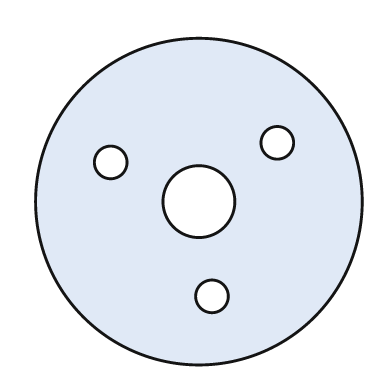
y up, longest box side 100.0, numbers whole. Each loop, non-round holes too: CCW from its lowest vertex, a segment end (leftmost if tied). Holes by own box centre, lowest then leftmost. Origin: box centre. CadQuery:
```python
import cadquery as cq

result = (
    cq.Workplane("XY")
    .moveTo(0.0, 0.0)
    .circle(50.0)
    .moveTo(4.0, -29.0)
    .circle(5.0)
    .moveTo(0.0, 0.0)
    .circle(11.0)
    .moveTo(-27.0, 12.0)
    .circle(5.0)
    .moveTo(24.0, 18.0)
    .circle(5.0)
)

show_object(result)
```